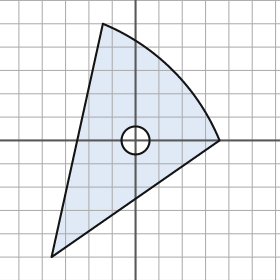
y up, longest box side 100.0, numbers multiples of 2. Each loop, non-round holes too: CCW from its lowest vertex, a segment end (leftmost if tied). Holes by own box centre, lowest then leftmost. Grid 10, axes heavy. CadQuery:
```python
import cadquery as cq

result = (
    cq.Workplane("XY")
    .moveTo(-36.0, -50.0)
    .lineTo(36.0, 0.0)
    .threePointArc((16.0, 30.0), (-14.0, 50.0))
    .close()
    .moveTo(0.0, 0.0)
    .circle(6.0)
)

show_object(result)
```